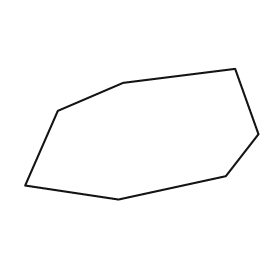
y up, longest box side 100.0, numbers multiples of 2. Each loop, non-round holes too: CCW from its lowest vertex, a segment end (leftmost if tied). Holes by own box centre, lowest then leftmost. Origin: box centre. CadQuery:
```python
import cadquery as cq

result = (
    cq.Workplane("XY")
    .moveTo(-10.0, -28.0)
    .lineTo(36.0, -18.0)
    .lineTo(50.0, 0.0)
    .lineTo(40.0, 28.0)
    .lineTo(-8.0, 22.0)
    .lineTo(-36.0, 10.0)
    .lineTo(-50.0, -22.0)
    .close()
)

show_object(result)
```